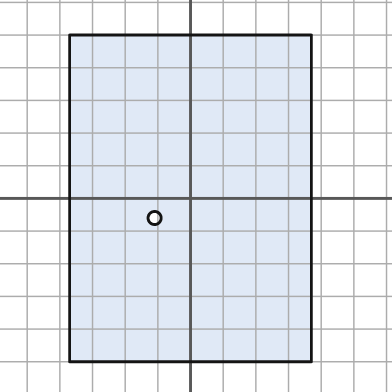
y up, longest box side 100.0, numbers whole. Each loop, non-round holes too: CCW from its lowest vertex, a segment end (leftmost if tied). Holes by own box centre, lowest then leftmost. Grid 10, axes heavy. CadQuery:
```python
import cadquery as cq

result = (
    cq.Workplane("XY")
    .moveTo(-37.0, -50.0)
    .lineTo(37.0, -50.0)
    .lineTo(37.0, 50.0)
    .lineTo(-37.0, 50.0)
    .close()
    .moveTo(-11.0, -6.0)
    .circle(2.0)
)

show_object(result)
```